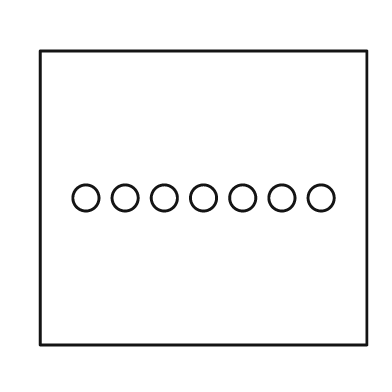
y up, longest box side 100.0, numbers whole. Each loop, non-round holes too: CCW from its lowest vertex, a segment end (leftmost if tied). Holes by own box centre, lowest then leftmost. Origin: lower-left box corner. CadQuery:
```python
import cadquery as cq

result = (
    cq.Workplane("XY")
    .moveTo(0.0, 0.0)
    .lineTo(100.0, 0.0)
    .lineTo(100.0, 90.0)
    .lineTo(0.0, 90.0)
    .close()
    .moveTo(14.0, 45.0)
    .circle(4.0)
    .moveTo(26.0, 45.0)
    .circle(4.0)
    .moveTo(38.0, 45.0)
    .circle(4.0)
    .moveTo(50.0, 45.0)
    .circle(4.0)
    .moveTo(62.0, 45.0)
    .circle(4.0)
    .moveTo(74.0, 45.0)
    .circle(4.0)
    .moveTo(86.0, 45.0)
    .circle(4.0)
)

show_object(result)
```